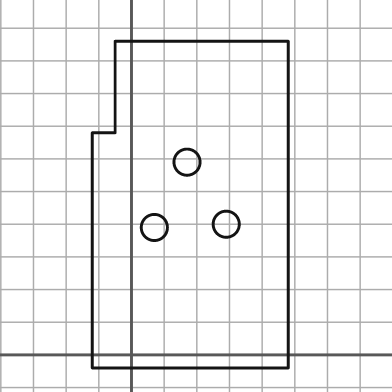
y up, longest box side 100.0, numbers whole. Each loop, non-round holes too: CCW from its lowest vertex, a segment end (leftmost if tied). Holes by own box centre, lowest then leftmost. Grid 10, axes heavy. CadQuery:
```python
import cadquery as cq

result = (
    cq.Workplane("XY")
    .moveTo(-12.0, -4.0)
    .lineTo(48.0, -4.0)
    .lineTo(48.0, 96.0)
    .lineTo(-5.0, 96.0)
    .lineTo(-5.0, 68.0)
    .lineTo(-12.0, 68.0)
    .close()
    .moveTo(7.0, 39.0)
    .circle(4.0)
    .moveTo(29.0, 40.0)
    .circle(4.0)
    .moveTo(17.0, 59.0)
    .circle(4.0)
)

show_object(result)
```